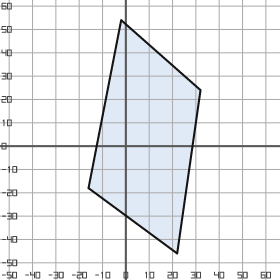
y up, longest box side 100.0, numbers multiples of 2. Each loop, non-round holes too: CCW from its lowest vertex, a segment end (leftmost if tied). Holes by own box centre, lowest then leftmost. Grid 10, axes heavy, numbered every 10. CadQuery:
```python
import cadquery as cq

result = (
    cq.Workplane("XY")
    .moveTo(22.0, -46.0)
    .lineTo(32.0, 24.0)
    .lineTo(-2.0, 54.0)
    .lineTo(-16.0, -18.0)
    .close()
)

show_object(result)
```